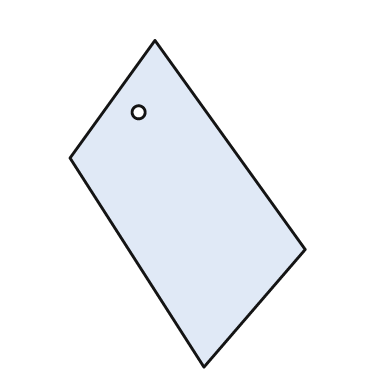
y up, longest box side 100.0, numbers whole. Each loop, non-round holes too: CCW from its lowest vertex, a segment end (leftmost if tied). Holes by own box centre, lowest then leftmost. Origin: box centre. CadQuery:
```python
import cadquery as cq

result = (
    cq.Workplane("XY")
    .moveTo(5.0, -50.0)
    .lineTo(36.0, -14.0)
    .lineTo(-10.0, 50.0)
    .lineTo(-36.0, 14.0)
    .close()
    .moveTo(-15.0, 28.0)
    .circle(2.0)
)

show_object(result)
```